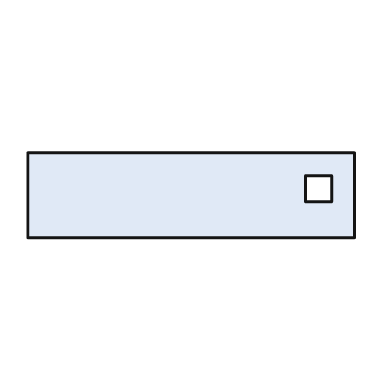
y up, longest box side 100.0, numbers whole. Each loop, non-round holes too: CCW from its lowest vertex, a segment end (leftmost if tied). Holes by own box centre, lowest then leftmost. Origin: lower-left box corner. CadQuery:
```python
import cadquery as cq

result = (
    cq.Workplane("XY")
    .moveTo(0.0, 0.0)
    .lineTo(100.0, 0.0)
    .lineTo(100.0, 26.0)
    .lineTo(0.0, 26.0)
    .close()
    .moveTo(85.0, 11.0)
    .lineTo(93.0, 11.0)
    .lineTo(93.0, 19.0)
    .lineTo(85.0, 19.0)
    .close()
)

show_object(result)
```